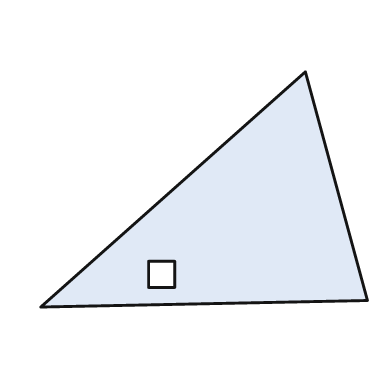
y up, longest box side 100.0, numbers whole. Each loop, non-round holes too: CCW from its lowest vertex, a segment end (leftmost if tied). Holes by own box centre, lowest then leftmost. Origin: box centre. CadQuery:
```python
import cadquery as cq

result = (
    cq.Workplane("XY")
    .moveTo(-50.0, -36.0)
    .lineTo(50.0, -34.0)
    .lineTo(31.0, 36.0)
    .close()
    .moveTo(-17.0, -30.0)
    .lineTo(-9.0, -30.0)
    .lineTo(-9.0, -22.0)
    .lineTo(-17.0, -22.0)
    .close()
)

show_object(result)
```